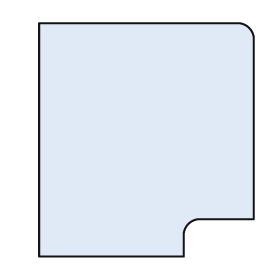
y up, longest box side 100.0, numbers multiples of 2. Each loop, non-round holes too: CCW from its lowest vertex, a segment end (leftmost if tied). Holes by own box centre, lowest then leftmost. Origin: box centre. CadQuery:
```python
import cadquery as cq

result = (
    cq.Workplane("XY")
    .moveTo(-46.0, -50.0)
    .lineTo(16.0, -50.0)
    .lineTo(16.0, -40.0)
    .threePointArc((18.0, -36.0), (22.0, -34.0))
    .lineTo(46.0, -34.0)
    .lineTo(46.0, 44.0)
    .threePointArc((44.0, 48.0), (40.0, 50.0))
    .lineTo(-46.0, 50.0)
    .close()
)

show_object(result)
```